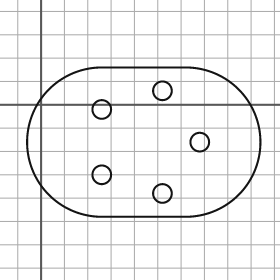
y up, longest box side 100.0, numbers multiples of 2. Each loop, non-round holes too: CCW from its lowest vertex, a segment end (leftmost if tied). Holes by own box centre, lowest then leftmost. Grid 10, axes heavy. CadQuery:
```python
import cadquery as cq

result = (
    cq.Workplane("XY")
    .moveTo(26.0, -48.0)
    .lineTo(62.0, -48.0)
    .threePointArc((94.0, -16.0), (62.0, 16.0))
    .lineTo(26.0, 16.0)
    .threePointArc((-6.0, -16.0), (26.0, -48.0))
    .close()
    .moveTo(52.0, -38.0)
    .circle(4.0)
    .moveTo(26.0, -30.0)
    .circle(4.0)
    .moveTo(68.0, -16.0)
    .circle(4.0)
    .moveTo(26.0, -2.0)
    .circle(4.0)
    .moveTo(52.0, 6.0)
    .circle(4.0)
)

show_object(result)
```